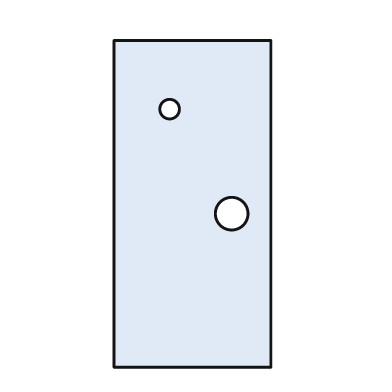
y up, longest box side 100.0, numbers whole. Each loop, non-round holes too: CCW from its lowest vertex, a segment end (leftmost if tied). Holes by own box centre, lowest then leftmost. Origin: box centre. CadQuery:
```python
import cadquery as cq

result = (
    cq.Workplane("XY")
    .moveTo(-24.0, -50.0)
    .lineTo(24.0, -50.0)
    .lineTo(24.0, 50.0)
    .lineTo(-24.0, 50.0)
    .close()
    .moveTo(12.0, -3.0)
    .circle(5.0)
    .moveTo(-7.0, 29.0)
    .circle(3.0)
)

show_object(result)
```